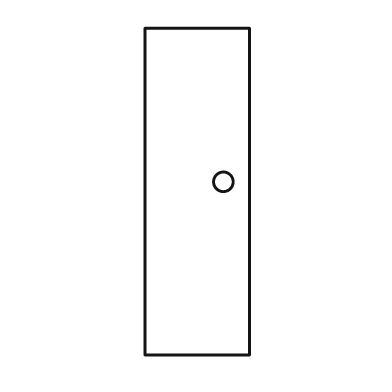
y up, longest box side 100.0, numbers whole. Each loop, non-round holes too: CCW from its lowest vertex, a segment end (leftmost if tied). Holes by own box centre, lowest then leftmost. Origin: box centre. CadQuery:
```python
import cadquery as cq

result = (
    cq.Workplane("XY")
    .moveTo(-16.0, -50.0)
    .lineTo(16.0, -50.0)
    .lineTo(16.0, 50.0)
    .lineTo(-16.0, 50.0)
    .close()
    .moveTo(8.0, 3.0)
    .circle(3.0)
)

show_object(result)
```